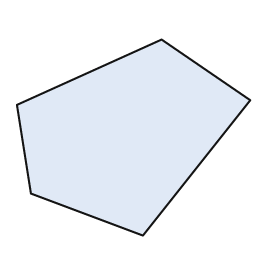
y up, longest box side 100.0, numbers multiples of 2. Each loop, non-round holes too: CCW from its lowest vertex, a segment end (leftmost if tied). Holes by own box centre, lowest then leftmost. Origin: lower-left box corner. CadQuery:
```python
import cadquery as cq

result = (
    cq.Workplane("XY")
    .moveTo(54.0, 0.0)
    .lineTo(100.0, 58.0)
    .lineTo(62.0, 84.0)
    .lineTo(0.0, 56.0)
    .lineTo(6.0, 18.0)
    .close()
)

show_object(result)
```